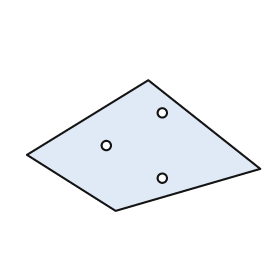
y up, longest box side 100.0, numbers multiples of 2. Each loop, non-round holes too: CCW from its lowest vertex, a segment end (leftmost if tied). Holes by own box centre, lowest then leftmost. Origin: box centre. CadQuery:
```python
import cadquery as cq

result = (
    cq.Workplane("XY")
    .moveTo(-12.0, -28.0)
    .lineTo(50.0, -10.0)
    .lineTo(2.0, 28.0)
    .lineTo(-50.0, -4.0)
    .close()
    .moveTo(8.0, -14.0)
    .circle(2.0)
    .moveTo(-16.0, 0.0)
    .circle(2.0)
    .moveTo(8.0, 14.0)
    .circle(2.0)
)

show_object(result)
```